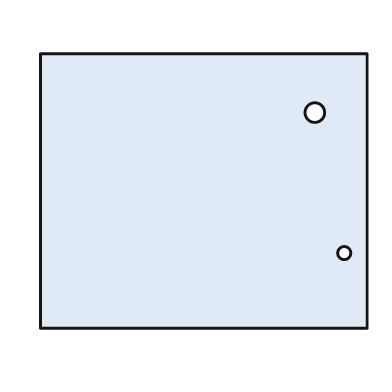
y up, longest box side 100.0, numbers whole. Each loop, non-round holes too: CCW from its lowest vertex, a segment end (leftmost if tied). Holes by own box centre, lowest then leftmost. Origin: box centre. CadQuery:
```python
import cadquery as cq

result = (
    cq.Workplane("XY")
    .moveTo(-50.0, -42.0)
    .lineTo(50.0, -42.0)
    .lineTo(50.0, 42.0)
    .lineTo(-50.0, 42.0)
    .close()
    .moveTo(43.0, -19.0)
    .circle(2.0)
    .moveTo(34.0, 24.0)
    .circle(3.0)
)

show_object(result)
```